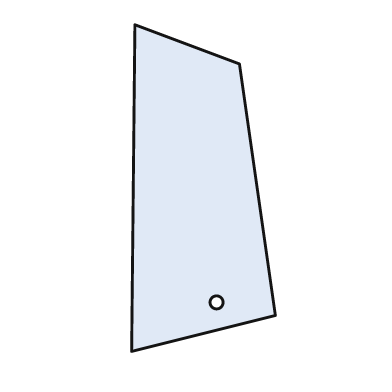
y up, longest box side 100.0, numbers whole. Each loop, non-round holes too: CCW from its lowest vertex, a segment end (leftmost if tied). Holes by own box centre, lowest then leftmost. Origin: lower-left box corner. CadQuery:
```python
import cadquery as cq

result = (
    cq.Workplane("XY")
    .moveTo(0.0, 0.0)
    .lineTo(44.0, 11.0)
    .lineTo(33.0, 88.0)
    .lineTo(1.0, 100.0)
    .close()
    .moveTo(26.0, 15.0)
    .circle(2.0)
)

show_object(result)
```